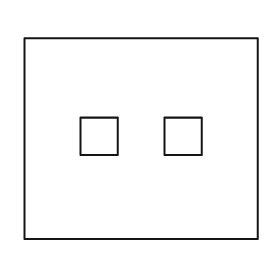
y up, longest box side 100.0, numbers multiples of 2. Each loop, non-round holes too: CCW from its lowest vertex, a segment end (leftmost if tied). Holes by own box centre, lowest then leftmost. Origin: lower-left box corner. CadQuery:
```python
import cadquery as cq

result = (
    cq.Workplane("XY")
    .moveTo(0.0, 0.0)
    .lineTo(100.0, 0.0)
    .lineTo(100.0, 86.0)
    .lineTo(0.0, 86.0)
    .close()
    .moveTo(24.0, 36.0)
    .lineTo(40.0, 36.0)
    .lineTo(40.0, 52.0)
    .lineTo(24.0, 52.0)
    .close()
    .moveTo(60.0, 36.0)
    .lineTo(76.0, 36.0)
    .lineTo(76.0, 52.0)
    .lineTo(60.0, 52.0)
    .close()
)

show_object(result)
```